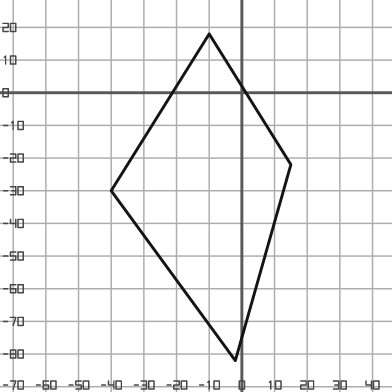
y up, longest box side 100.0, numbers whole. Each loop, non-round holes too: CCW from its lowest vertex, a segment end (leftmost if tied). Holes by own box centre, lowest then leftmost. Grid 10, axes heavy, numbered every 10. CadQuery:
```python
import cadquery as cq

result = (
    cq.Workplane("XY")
    .moveTo(-2.0, -82.0)
    .lineTo(15.0, -22.0)
    .lineTo(-10.0, 18.0)
    .lineTo(-40.0, -30.0)
    .close()
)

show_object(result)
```